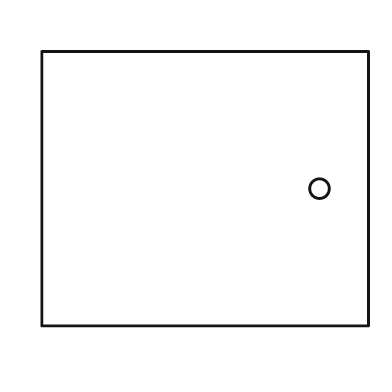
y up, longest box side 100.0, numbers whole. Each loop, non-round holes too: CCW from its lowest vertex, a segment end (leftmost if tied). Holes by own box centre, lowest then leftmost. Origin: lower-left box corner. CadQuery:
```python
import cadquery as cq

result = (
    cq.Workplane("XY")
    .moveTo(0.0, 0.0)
    .lineTo(100.0, 0.0)
    .lineTo(100.0, 84.0)
    .lineTo(0.0, 84.0)
    .close()
    .moveTo(85.0, 42.0)
    .circle(3.0)
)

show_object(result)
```